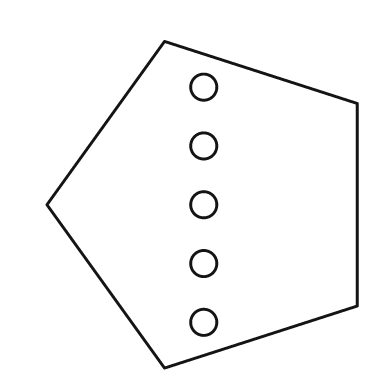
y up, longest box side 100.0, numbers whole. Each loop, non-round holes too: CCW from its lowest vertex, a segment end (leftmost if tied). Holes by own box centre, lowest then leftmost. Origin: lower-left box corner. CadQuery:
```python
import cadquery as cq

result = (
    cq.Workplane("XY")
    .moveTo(36.0, 0.0)
    .lineTo(95.0, 19.0)
    .lineTo(95.0, 81.0)
    .lineTo(36.0, 100.0)
    .lineTo(0.0, 50.0)
    .close()
    .moveTo(48.0, 14.0)
    .circle(4.0)
    .moveTo(48.0, 32.0)
    .circle(4.0)
    .moveTo(48.0, 50.0)
    .circle(4.0)
    .moveTo(48.0, 68.0)
    .circle(4.0)
    .moveTo(48.0, 86.0)
    .circle(4.0)
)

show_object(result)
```